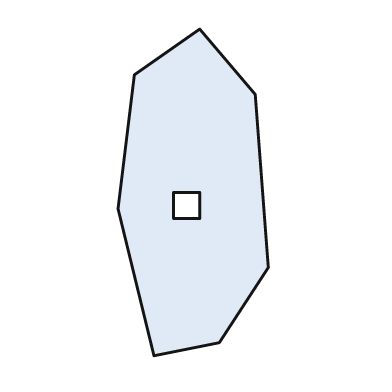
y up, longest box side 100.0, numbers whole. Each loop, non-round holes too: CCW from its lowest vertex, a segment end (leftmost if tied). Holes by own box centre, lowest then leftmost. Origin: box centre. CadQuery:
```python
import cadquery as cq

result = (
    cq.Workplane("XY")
    .moveTo(-12.0, -50.0)
    .lineTo(8.0, -46.0)
    .lineTo(23.0, -23.0)
    .lineTo(19.0, 30.0)
    .lineTo(2.0, 50.0)
    .lineTo(-18.0, 36.0)
    .lineTo(-23.0, -5.0)
    .close()
    .moveTo(-6.0, -8.0)
    .lineTo(2.0, -8.0)
    .lineTo(2.0, 0.0)
    .lineTo(-6.0, 0.0)
    .close()
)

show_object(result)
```